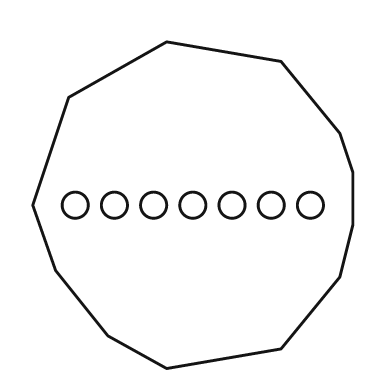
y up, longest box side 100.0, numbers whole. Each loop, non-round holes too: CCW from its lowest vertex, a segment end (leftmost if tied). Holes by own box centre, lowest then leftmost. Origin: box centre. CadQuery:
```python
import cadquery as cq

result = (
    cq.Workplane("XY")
    .moveTo(-8.0, -50.0)
    .lineTo(27.0, -44.0)
    .lineTo(45.0, -22.0)
    .lineTo(49.0, -6.0)
    .lineTo(49.0, 10.0)
    .lineTo(45.0, 22.0)
    .lineTo(27.0, 44.0)
    .lineTo(-8.0, 50.0)
    .lineTo(-38.0, 33.0)
    .lineTo(-49.0, 0.0)
    .lineTo(-42.0, -20.0)
    .lineTo(-26.0, -40.0)
    .close()
    .moveTo(-36.0, 0.0)
    .circle(4.0)
    .moveTo(-24.0, 0.0)
    .circle(4.0)
    .moveTo(-12.0, 0.0)
    .circle(4.0)
    .moveTo(0.0, 0.0)
    .circle(4.0)
    .moveTo(12.0, 0.0)
    .circle(4.0)
    .moveTo(24.0, 0.0)
    .circle(4.0)
    .moveTo(36.0, 0.0)
    .circle(4.0)
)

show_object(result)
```